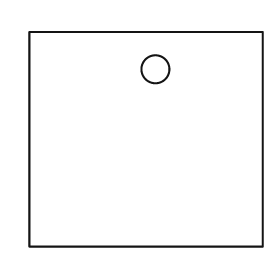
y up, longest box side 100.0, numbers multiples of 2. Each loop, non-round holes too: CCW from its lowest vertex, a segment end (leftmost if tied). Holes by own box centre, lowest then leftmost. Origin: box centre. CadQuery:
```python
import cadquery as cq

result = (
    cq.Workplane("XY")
    .moveTo(-50.0, -46.0)
    .lineTo(50.0, -46.0)
    .lineTo(50.0, 46.0)
    .lineTo(-50.0, 46.0)
    .close()
    .moveTo(4.0, 30.0)
    .circle(6.0)
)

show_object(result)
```